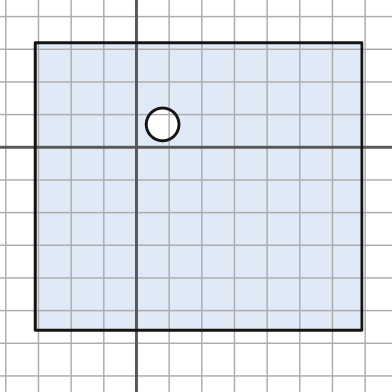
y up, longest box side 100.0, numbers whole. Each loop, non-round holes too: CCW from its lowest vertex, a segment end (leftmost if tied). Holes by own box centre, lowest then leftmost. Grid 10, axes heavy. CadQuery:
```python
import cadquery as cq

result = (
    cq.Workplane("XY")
    .moveTo(-31.0, -56.0)
    .lineTo(69.0, -56.0)
    .lineTo(69.0, 32.0)
    .lineTo(-31.0, 32.0)
    .close()
    .moveTo(8.0, 7.0)
    .circle(5.0)
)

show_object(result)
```